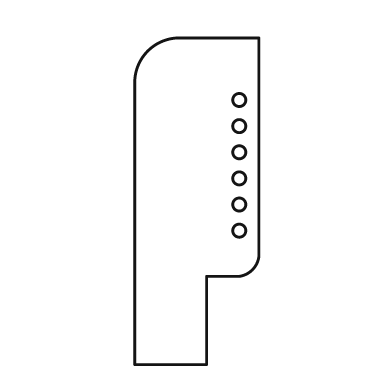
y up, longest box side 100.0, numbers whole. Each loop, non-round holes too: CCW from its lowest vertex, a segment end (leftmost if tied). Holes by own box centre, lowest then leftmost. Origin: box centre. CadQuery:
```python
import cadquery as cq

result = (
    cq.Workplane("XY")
    .moveTo(-19.0, -50.0)
    .lineTo(3.0, -50.0)
    .lineTo(3.0, -23.0)
    .lineTo(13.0, -23.0)
    .threePointArc((17.0, -21.0), (19.0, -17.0))
    .lineTo(19.0, 50.0)
    .lineTo(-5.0, 50.0)
    .threePointArc((-15.0, 46.0), (-19.0, 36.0))
    .close()
    .moveTo(13.0, -9.0)
    .circle(2.0)
    .moveTo(13.0, -1.0)
    .circle(2.0)
    .moveTo(13.0, 7.0)
    .circle(2.0)
    .moveTo(13.0, 15.0)
    .circle(2.0)
    .moveTo(13.0, 23.0)
    .circle(2.0)
    .moveTo(13.0, 31.0)
    .circle(2.0)
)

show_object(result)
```